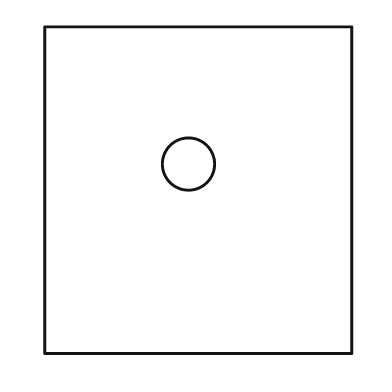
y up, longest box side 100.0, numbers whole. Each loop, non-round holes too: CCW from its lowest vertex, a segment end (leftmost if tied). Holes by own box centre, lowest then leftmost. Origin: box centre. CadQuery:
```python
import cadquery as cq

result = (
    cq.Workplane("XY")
    .moveTo(-47.0, -50.0)
    .lineTo(47.0, -50.0)
    .lineTo(47.0, 50.0)
    .lineTo(-47.0, 50.0)
    .close()
    .moveTo(-3.0, 8.0)
    .circle(8.0)
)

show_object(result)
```